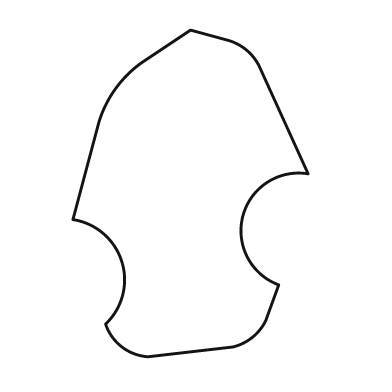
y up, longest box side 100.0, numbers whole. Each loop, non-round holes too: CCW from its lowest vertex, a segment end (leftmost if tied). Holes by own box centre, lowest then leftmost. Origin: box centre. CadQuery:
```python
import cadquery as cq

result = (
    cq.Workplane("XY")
    .moveTo(-13.0, -50.0)
    .lineTo(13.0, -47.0)
    .threePointArc((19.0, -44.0), (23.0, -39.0))
    .lineTo(27.0, -28.0)
    .threePointArc((16.0, -7.0), (36.0, 6.0))
    .lineTo(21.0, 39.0)
    .threePointArc((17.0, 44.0), (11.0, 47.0))
    .lineTo(0.0, 50.0)
    .lineTo(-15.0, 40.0)
    .threePointArc((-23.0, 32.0), (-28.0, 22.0))
    .lineTo(-36.0, -8.0)
    .threePointArc((-21.0, -21.0), (-26.0, -40.0))
    .threePointArc((-21.0, -47.0), (-13.0, -50.0))
    .close()
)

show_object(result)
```